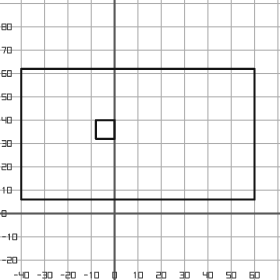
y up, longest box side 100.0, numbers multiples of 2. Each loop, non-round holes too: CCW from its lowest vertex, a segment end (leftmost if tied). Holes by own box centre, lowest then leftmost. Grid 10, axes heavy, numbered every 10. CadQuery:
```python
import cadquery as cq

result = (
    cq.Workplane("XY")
    .moveTo(-40.0, 6.0)
    .lineTo(60.0, 6.0)
    .lineTo(60.0, 62.0)
    .lineTo(-40.0, 62.0)
    .close()
    .moveTo(-8.0, 32.0)
    .lineTo(0.0, 32.0)
    .lineTo(0.0, 40.0)
    .lineTo(-8.0, 40.0)
    .close()
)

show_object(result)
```